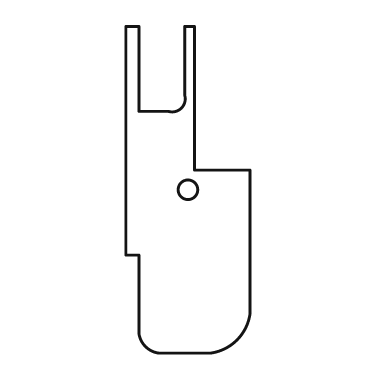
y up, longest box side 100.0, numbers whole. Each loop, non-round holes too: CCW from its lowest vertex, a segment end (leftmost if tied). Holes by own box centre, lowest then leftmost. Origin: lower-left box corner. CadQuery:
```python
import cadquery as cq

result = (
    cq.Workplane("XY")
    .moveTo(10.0, 0.0)
    .lineTo(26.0, 0.0)
    .threePointArc((34.0, 4.0), (38.0, 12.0))
    .lineTo(38.0, 56.0)
    .lineTo(21.0, 56.0)
    .lineTo(21.0, 100.0)
    .lineTo(18.0, 100.0)
    .lineTo(18.0, 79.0)
    .threePointArc((17.0, 75.0), (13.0, 74.0))
    .lineTo(4.0, 74.0)
    .lineTo(4.0, 100.0)
    .lineTo(0.0, 100.0)
    .lineTo(0.0, 30.0)
    .lineTo(4.0, 30.0)
    .lineTo(4.0, 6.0)
    .threePointArc((6.0, 2.0), (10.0, 0.0))
    .close()
    .moveTo(19.0, 50.0)
    .circle(3.0)
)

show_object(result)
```